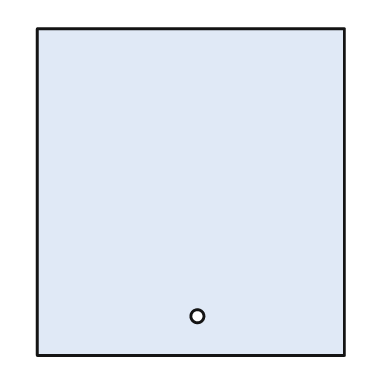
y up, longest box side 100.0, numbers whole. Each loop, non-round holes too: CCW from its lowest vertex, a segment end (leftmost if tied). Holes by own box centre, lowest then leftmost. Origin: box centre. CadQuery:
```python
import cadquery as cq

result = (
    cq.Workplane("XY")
    .moveTo(-47.0, -50.0)
    .lineTo(47.0, -50.0)
    .lineTo(47.0, 50.0)
    .lineTo(-47.0, 50.0)
    .close()
    .moveTo(2.0, -38.0)
    .circle(2.0)
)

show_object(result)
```